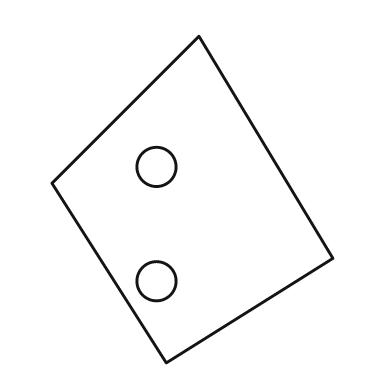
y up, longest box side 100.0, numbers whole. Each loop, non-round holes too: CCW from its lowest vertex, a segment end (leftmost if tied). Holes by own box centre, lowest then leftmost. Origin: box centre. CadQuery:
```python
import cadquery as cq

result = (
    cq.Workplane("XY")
    .moveTo(-8.0, -50.0)
    .lineTo(43.0, -18.0)
    .lineTo(2.0, 50.0)
    .lineTo(-43.0, 5.0)
    .close()
    .moveTo(-11.0, -25.0)
    .circle(6.0)
    .moveTo(-11.0, 10.0)
    .circle(6.0)
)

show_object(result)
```